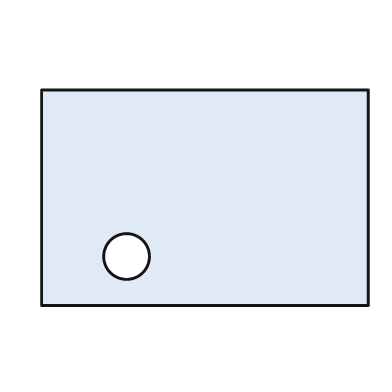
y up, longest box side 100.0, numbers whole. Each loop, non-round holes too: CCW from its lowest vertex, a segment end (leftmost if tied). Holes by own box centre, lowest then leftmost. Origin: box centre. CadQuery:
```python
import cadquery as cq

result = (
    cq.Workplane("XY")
    .moveTo(-50.0, -33.0)
    .lineTo(50.0, -33.0)
    .lineTo(50.0, 33.0)
    .lineTo(-50.0, 33.0)
    .close()
    .moveTo(-24.0, -18.0)
    .circle(7.0)
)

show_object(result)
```